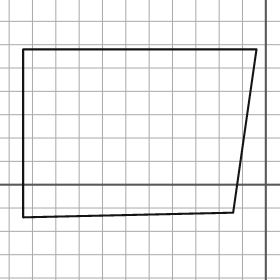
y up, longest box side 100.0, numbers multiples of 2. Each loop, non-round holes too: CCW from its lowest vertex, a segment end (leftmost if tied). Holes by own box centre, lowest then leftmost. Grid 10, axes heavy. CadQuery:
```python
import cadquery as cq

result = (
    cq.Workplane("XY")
    .moveTo(-104.0, -14.0)
    .lineTo(-14.0, -12.0)
    .lineTo(-4.0, 58.0)
    .lineTo(-104.0, 58.0)
    .close()
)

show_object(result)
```